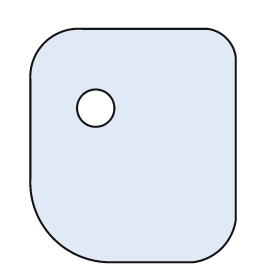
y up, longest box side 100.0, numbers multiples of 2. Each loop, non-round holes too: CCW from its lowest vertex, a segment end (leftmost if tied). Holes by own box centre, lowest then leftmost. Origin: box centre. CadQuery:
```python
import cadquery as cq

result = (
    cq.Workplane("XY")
    .moveTo(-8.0, -50.0)
    .lineTo(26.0, -50.0)
    .threePointArc((38.0, -44.0), (44.0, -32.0))
    .lineTo(44.0, 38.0)
    .threePointArc((40.0, 46.0), (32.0, 50.0))
    .lineTo(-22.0, 50.0)
    .threePointArc((-38.0, 44.0), (-44.0, 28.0))
    .lineTo(-44.0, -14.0)
    .threePointArc((-34.0, -40.0), (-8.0, -50.0))
    .close()
    .moveTo(-16.0, 16.0)
    .circle(8.0)
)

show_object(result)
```